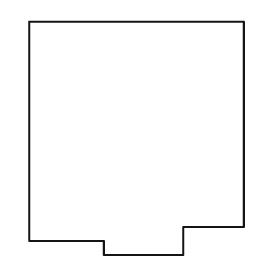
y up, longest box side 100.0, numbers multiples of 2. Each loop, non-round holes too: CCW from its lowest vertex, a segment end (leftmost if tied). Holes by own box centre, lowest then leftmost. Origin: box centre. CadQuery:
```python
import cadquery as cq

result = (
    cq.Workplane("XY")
    .moveTo(-14.0, -50.0)
    .lineTo(20.0, -50.0)
    .lineTo(20.0, -38.0)
    .lineTo(46.0, -38.0)
    .lineTo(46.0, 50.0)
    .lineTo(-46.0, 50.0)
    .lineTo(-46.0, -44.0)
    .lineTo(-14.0, -44.0)
    .close()
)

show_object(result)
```